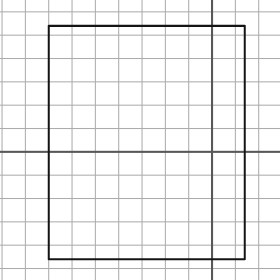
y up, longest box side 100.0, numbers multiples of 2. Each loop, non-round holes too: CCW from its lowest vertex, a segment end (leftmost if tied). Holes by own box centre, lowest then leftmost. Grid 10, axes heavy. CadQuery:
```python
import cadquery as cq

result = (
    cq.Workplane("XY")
    .moveTo(-70.0, -46.0)
    .lineTo(14.0, -46.0)
    .lineTo(14.0, 54.0)
    .lineTo(-70.0, 54.0)
    .close()
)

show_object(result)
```